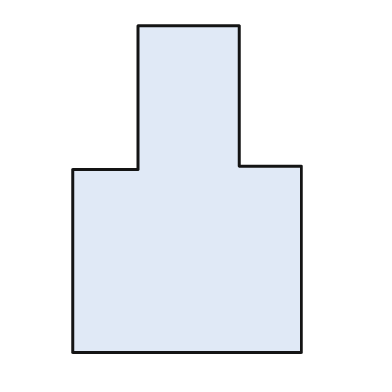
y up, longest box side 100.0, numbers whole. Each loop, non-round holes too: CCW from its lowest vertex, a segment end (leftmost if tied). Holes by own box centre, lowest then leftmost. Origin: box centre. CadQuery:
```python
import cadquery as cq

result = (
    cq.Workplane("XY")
    .moveTo(-35.0, -50.0)
    .lineTo(35.0, -50.0)
    .lineTo(35.0, 7.0)
    .lineTo(16.0, 7.0)
    .lineTo(16.0, 50.0)
    .lineTo(-15.0, 50.0)
    .lineTo(-15.0, 6.0)
    .lineTo(-35.0, 6.0)
    .close()
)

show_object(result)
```